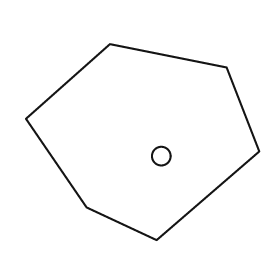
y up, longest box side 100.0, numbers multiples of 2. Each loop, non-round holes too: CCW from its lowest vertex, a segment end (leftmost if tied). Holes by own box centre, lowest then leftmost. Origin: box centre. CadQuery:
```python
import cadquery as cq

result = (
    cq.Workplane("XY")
    .moveTo(6.0, -42.0)
    .lineTo(50.0, -4.0)
    .lineTo(36.0, 32.0)
    .lineTo(-14.0, 42.0)
    .lineTo(-50.0, 10.0)
    .lineTo(-24.0, -28.0)
    .close()
    .moveTo(8.0, -6.0)
    .circle(4.0)
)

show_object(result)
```